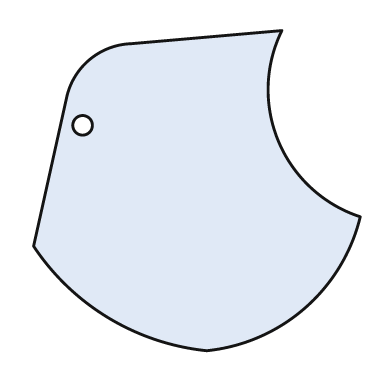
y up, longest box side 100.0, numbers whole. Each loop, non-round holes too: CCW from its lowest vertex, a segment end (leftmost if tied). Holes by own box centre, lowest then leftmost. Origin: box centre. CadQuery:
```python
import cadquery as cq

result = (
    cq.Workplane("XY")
    .moveTo(3.0, -49.0)
    .threePointArc((33.0, -36.0), (50.0, -8.0))
    .threePointArc((25.0, 15.0), (26.0, 49.0))
    .lineTo(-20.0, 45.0)
    .threePointArc((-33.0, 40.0), (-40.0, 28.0))
    .lineTo(-50.0, -17.0)
    .threePointArc((-27.0, -39.0), (3.0, -49.0))
    .close()
    .moveTo(-35.0, 20.0)
    .circle(3.0)
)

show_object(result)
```